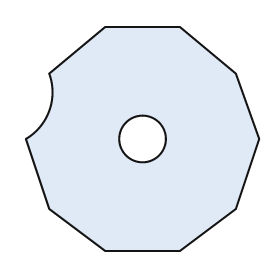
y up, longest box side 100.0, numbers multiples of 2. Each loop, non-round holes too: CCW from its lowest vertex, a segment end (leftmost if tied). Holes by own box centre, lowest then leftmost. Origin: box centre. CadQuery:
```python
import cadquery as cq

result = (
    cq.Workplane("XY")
    .moveTo(-16.0, -48.0)
    .lineTo(16.0, -48.0)
    .lineTo(40.0, -30.0)
    .lineTo(50.0, 0.0)
    .lineTo(40.0, 28.0)
    .lineTo(16.0, 48.0)
    .lineTo(-16.0, 48.0)
    .lineTo(-40.0, 28.0)
    .threePointArc((-40.0, 12.0), (-50.0, 0.0))
    .lineTo(-40.0, -30.0)
    .close()
    .moveTo(0.0, 0.0)
    .circle(10.0)
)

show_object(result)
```